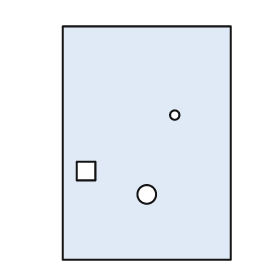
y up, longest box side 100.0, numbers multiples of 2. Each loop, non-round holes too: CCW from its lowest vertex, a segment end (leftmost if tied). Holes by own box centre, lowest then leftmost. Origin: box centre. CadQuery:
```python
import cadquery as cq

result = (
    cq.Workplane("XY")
    .moveTo(-36.0, -50.0)
    .lineTo(36.0, -50.0)
    .lineTo(36.0, 50.0)
    .lineTo(-36.0, 50.0)
    .close()
    .moveTo(0.0, -22.0)
    .circle(4.0)
    .moveTo(-30.0, -16.0)
    .lineTo(-22.0, -16.0)
    .lineTo(-22.0, -8.0)
    .lineTo(-30.0, -8.0)
    .close()
    .moveTo(12.0, 12.0)
    .circle(2.0)
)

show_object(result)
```